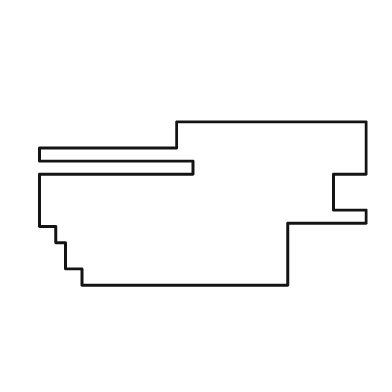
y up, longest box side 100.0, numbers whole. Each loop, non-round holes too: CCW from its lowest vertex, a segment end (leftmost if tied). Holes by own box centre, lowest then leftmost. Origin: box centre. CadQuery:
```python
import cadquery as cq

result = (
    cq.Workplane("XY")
    .moveTo(-37.0, -25.0)
    .lineTo(26.0, -25.0)
    .lineTo(26.0, -6.0)
    .lineTo(50.0, -6.0)
    .lineTo(50.0, -2.0)
    .lineTo(40.0, -2.0)
    .lineTo(40.0, 9.0)
    .lineTo(50.0, 9.0)
    .lineTo(50.0, 25.0)
    .lineTo(-8.0, 25.0)
    .lineTo(-8.0, 17.0)
    .lineTo(-50.0, 17.0)
    .lineTo(-50.0, 13.0)
    .lineTo(-3.0, 13.0)
    .lineTo(-3.0, 9.0)
    .lineTo(-50.0, 9.0)
    .lineTo(-50.0, -7.0)
    .lineTo(-45.0, -7.0)
    .lineTo(-45.0, -12.0)
    .lineTo(-42.0, -12.0)
    .lineTo(-42.0, -20.0)
    .lineTo(-37.0, -20.0)
    .close()
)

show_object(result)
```